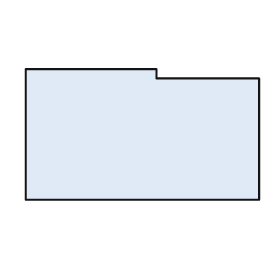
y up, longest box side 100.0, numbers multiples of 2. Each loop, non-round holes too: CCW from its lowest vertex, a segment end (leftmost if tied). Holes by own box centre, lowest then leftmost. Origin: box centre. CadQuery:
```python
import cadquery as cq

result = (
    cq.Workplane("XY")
    .moveTo(-50.0, -28.0)
    .lineTo(50.0, -28.0)
    .lineTo(50.0, 24.0)
    .lineTo(6.0, 24.0)
    .lineTo(6.0, 28.0)
    .lineTo(-50.0, 28.0)
    .close()
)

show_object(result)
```